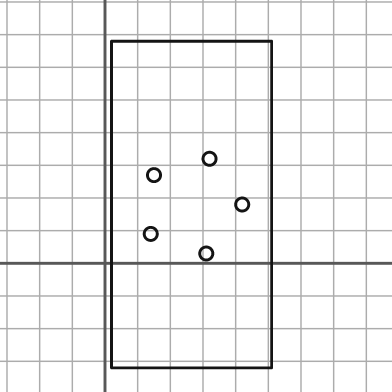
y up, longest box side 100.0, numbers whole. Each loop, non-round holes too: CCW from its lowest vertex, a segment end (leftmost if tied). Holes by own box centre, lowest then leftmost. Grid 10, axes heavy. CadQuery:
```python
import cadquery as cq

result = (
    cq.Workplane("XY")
    .moveTo(2.0, -32.0)
    .lineTo(51.0, -32.0)
    .lineTo(51.0, 68.0)
    .lineTo(2.0, 68.0)
    .close()
    .moveTo(31.0, 3.0)
    .circle(2.0)
    .moveTo(14.0, 9.0)
    .circle(2.0)
    .moveTo(42.0, 18.0)
    .circle(2.0)
    .moveTo(15.0, 27.0)
    .circle(2.0)
    .moveTo(32.0, 32.0)
    .circle(2.0)
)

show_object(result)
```